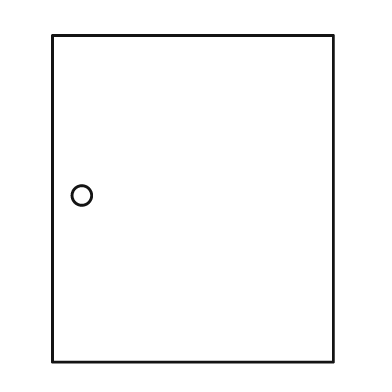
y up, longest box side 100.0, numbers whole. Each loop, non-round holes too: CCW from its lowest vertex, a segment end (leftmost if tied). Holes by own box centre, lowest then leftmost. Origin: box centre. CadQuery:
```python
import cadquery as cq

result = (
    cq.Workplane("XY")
    .moveTo(-43.0, -50.0)
    .lineTo(43.0, -50.0)
    .lineTo(43.0, 50.0)
    .lineTo(-43.0, 50.0)
    .close()
    .moveTo(-34.0, 1.0)
    .circle(3.0)
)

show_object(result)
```